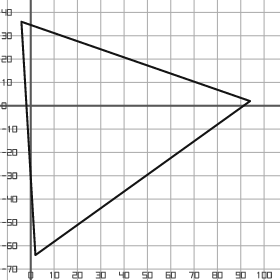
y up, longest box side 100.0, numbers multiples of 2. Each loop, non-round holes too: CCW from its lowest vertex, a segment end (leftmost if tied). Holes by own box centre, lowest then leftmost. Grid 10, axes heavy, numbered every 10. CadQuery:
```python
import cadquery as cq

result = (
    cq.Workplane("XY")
    .moveTo(2.0, -64.0)
    .lineTo(94.0, 2.0)
    .lineTo(-4.0, 36.0)
    .close()
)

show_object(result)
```